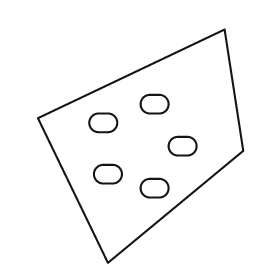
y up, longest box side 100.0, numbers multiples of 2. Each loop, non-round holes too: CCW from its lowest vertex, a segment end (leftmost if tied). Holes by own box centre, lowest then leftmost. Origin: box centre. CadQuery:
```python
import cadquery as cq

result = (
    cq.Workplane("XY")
    .moveTo(-14.0, -50.0)
    .lineTo(44.0, -2.0)
    .lineTo(36.0, 50.0)
    .lineTo(-44.0, 12.0)
    .close()
    .moveTo(4.0, -22.0)
    .lineTo(8.0, -22.0)
    .threePointArc((12.0, -18.0), (8.0, -14.0))
    .lineTo(4.0, -14.0)
    .threePointArc((0.0, -18.0), (4.0, -22.0))
    .close()
    .moveTo(-16.0, -16.0)
    .lineTo(-12.0, -16.0)
    .threePointArc((-8.0, -12.0), (-12.0, -8.0))
    .lineTo(-16.0, -8.0)
    .threePointArc((-20.0, -12.0), (-16.0, -16.0))
    .close()
    .moveTo(16.0, -4.0)
    .lineTo(20.0, -4.0)
    .threePointArc((24.0, 0.0), (20.0, 4.0))
    .lineTo(16.0, 4.0)
    .threePointArc((12.0, 0.0), (16.0, -4.0))
    .close()
    .moveTo(-18.0, 6.0)
    .lineTo(-14.0, 6.0)
    .threePointArc((-10.0, 10.0), (-14.0, 14.0))
    .lineTo(-18.0, 14.0)
    .threePointArc((-22.0, 10.0), (-18.0, 6.0))
    .close()
    .moveTo(4.0, 14.0)
    .lineTo(8.0, 14.0)
    .threePointArc((12.0, 18.0), (8.0, 22.0))
    .lineTo(4.0, 22.0)
    .threePointArc((0.0, 18.0), (4.0, 14.0))
    .close()
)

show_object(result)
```